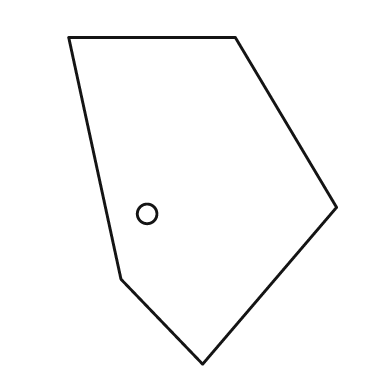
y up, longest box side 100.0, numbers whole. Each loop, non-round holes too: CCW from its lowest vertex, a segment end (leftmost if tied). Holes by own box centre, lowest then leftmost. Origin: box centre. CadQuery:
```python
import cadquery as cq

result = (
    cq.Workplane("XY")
    .moveTo(0.0, -50.0)
    .lineTo(41.0, -2.0)
    .lineTo(10.0, 50.0)
    .lineTo(-41.0, 50.0)
    .lineTo(-25.0, -24.0)
    .close()
    .moveTo(-17.0, -4.0)
    .circle(3.0)
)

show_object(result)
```